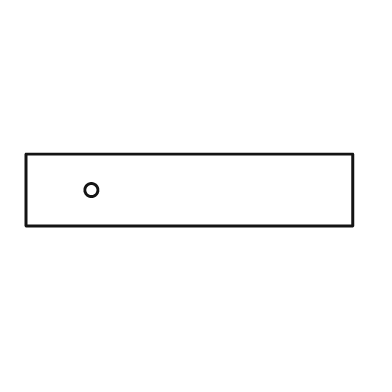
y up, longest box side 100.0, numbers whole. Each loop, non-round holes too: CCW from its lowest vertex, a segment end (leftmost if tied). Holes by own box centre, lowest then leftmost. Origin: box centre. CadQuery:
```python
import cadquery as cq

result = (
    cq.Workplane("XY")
    .moveTo(-50.0, -11.0)
    .lineTo(50.0, -11.0)
    .lineTo(50.0, 11.0)
    .lineTo(-50.0, 11.0)
    .close()
    .moveTo(-30.0, 0.0)
    .circle(2.0)
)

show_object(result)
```